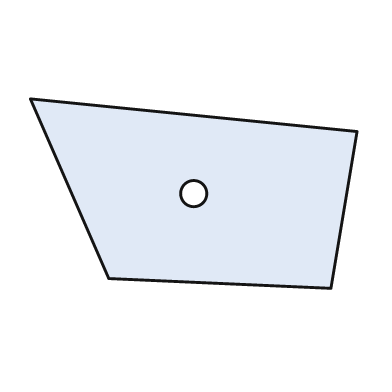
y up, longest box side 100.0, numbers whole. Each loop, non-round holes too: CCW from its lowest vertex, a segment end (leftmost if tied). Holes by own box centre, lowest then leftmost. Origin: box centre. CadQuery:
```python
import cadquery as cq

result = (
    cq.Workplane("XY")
    .moveTo(42.0, -29.0)
    .lineTo(50.0, 19.0)
    .lineTo(-50.0, 29.0)
    .lineTo(-26.0, -26.0)
    .close()
    .moveTo(0.0, 0.0)
    .circle(4.0)
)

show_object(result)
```